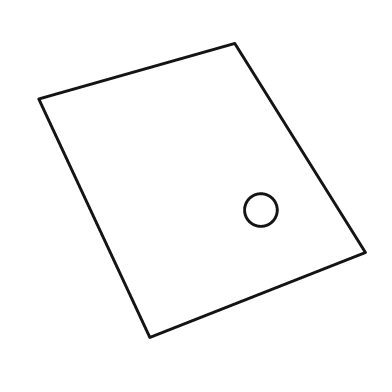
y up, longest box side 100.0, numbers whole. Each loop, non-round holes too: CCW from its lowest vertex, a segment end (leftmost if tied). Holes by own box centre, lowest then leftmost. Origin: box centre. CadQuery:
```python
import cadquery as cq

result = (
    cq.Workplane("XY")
    .moveTo(-16.0, -45.0)
    .lineTo(50.0, -19.0)
    .lineTo(10.0, 45.0)
    .lineTo(-50.0, 28.0)
    .close()
    .moveTo(18.0, -6.0)
    .circle(5.0)
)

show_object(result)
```